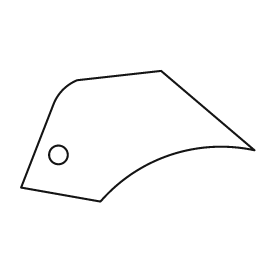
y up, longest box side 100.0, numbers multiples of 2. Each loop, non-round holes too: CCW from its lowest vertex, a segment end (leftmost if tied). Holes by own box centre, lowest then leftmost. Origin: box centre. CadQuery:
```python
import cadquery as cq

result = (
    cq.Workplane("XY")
    .moveTo(-16.0, -28.0)
    .threePointArc((14.0, -8.0), (50.0, -6.0))
    .lineTo(10.0, 28.0)
    .lineTo(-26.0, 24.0)
    .threePointArc((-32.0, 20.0), (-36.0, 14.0))
    .lineTo(-50.0, -22.0)
    .close()
    .moveTo(-34.0, -8.0)
    .circle(4.0)
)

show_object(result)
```